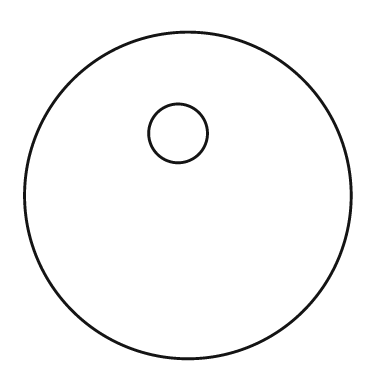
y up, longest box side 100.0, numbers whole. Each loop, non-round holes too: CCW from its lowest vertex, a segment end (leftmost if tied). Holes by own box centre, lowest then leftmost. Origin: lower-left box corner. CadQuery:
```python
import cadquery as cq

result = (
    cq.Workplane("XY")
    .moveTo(50.0, 50.0)
    .circle(50.0)
    .moveTo(47.0, 69.0)
    .circle(9.0)
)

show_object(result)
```